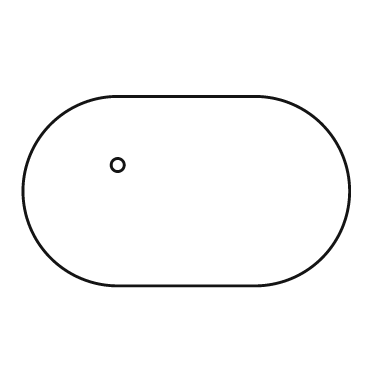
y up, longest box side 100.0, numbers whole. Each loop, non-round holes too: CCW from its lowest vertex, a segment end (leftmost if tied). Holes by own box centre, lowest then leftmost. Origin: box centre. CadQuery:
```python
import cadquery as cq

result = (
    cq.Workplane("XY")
    .moveTo(-21.0, -29.0)
    .lineTo(21.0, -29.0)
    .threePointArc((50.0, 0.0), (21.0, 29.0))
    .lineTo(-21.0, 29.0)
    .threePointArc((-50.0, 0.0), (-21.0, -29.0))
    .close()
    .moveTo(-21.0, 8.0)
    .circle(2.0)
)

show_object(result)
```